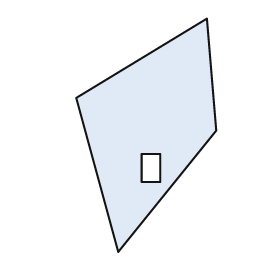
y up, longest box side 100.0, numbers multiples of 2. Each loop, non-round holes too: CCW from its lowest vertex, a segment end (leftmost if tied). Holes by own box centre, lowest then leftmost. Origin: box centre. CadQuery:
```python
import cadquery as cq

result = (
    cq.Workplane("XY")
    .moveTo(-12.0, -50.0)
    .lineTo(30.0, 2.0)
    .lineTo(26.0, 50.0)
    .lineTo(-30.0, 16.0)
    .close()
    .moveTo(-2.0, -20.0)
    .lineTo(6.0, -20.0)
    .lineTo(6.0, -8.0)
    .lineTo(-2.0, -8.0)
    .close()
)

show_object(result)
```